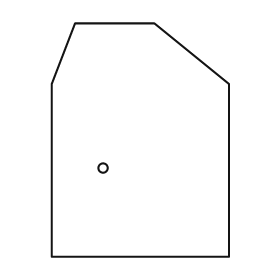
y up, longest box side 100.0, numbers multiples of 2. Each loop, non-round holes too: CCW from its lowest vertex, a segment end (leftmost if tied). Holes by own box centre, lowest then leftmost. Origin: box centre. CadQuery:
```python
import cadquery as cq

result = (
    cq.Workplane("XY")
    .moveTo(-38.0, -50.0)
    .lineTo(38.0, -50.0)
    .lineTo(38.0, 24.0)
    .lineTo(6.0, 50.0)
    .lineTo(-28.0, 50.0)
    .lineTo(-38.0, 24.0)
    .close()
    .moveTo(-16.0, -12.0)
    .circle(2.0)
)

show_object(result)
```